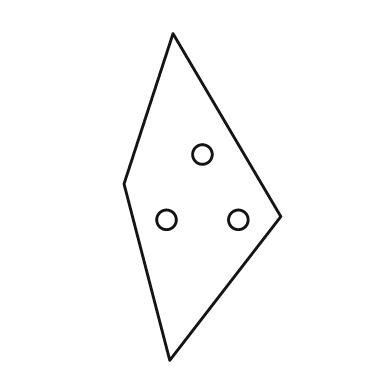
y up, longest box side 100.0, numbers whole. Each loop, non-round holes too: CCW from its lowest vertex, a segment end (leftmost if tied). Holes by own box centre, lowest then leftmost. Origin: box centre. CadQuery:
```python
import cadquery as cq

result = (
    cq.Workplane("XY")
    .moveTo(-10.0, -50.0)
    .lineTo(24.0, -6.0)
    .lineTo(-9.0, 50.0)
    .lineTo(-24.0, 4.0)
    .close()
    .moveTo(-11.0, -7.0)
    .circle(3.0)
    .moveTo(11.0, -7.0)
    .circle(3.0)
    .moveTo(0.0, 13.0)
    .circle(3.0)
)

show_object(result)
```